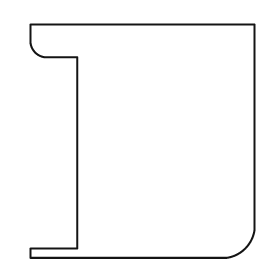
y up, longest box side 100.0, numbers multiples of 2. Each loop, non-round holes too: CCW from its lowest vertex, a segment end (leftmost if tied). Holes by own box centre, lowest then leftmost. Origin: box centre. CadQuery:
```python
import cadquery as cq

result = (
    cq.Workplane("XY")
    .moveTo(-48.0, -50.0)
    .lineTo(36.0, -50.0)
    .threePointArc((44.0, -46.0), (48.0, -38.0))
    .lineTo(48.0, 50.0)
    .lineTo(-48.0, 50.0)
    .lineTo(-48.0, 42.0)
    .threePointArc((-46.0, 38.0), (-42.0, 36.0))
    .lineTo(-28.0, 36.0)
    .lineTo(-28.0, -46.0)
    .lineTo(-48.0, -46.0)
    .close()
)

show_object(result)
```